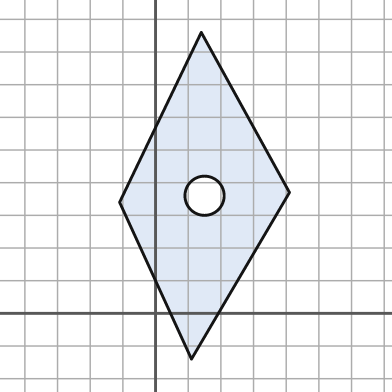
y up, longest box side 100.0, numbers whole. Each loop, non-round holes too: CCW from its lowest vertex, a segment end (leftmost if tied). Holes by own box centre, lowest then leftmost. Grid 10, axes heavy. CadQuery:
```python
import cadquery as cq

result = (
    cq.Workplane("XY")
    .moveTo(11.0, -14.0)
    .lineTo(41.0, 37.0)
    .lineTo(14.0, 86.0)
    .lineTo(-11.0, 34.0)
    .close()
    .moveTo(15.0, 36.0)
    .circle(6.0)
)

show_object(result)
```